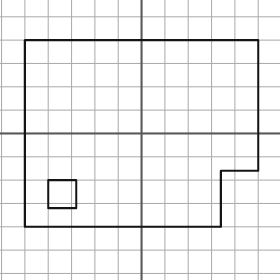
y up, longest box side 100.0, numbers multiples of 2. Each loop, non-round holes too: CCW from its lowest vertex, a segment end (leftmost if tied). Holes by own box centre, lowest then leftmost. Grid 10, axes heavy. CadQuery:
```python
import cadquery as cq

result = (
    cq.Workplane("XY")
    .moveTo(-50.0, -40.0)
    .lineTo(34.0, -40.0)
    .lineTo(34.0, -16.0)
    .lineTo(50.0, -16.0)
    .lineTo(50.0, 40.0)
    .lineTo(-50.0, 40.0)
    .close()
    .moveTo(-40.0, -32.0)
    .lineTo(-28.0, -32.0)
    .lineTo(-28.0, -20.0)
    .lineTo(-40.0, -20.0)
    .close()
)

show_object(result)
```